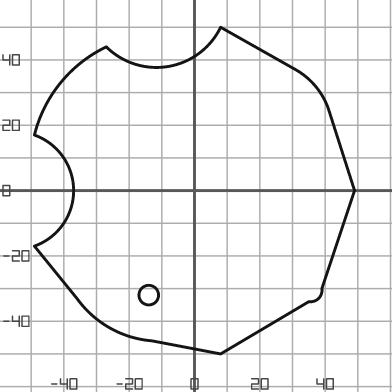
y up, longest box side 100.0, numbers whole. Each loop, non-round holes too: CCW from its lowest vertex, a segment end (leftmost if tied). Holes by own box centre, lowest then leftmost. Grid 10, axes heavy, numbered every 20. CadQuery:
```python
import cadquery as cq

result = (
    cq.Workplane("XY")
    .moveTo(8.0, -50.0)
    .lineTo(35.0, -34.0)
    .threePointArc((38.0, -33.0), (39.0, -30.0))
    .lineTo(49.0, 0.0)
    .lineTo(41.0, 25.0)
    .threePointArc((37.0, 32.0), (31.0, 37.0))
    .lineTo(8.0, 50.0)
    .threePointArc((-8.0, 38.0), (-27.0, 44.0))
    .threePointArc((-41.0, 33.0), (-49.0, 17.0))
    .threePointArc((-37.0, 0.0), (-49.0, -17.0))
    .lineTo(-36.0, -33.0)
    .threePointArc((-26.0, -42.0), (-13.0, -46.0))
    .close()
    .moveTo(-14.0, -32.0)
    .circle(3.0)
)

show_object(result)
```